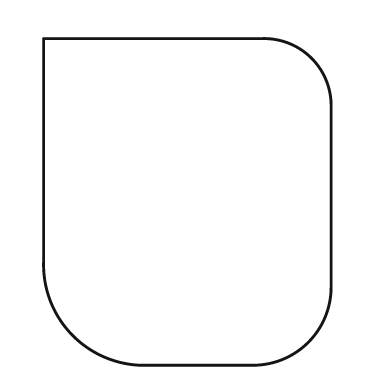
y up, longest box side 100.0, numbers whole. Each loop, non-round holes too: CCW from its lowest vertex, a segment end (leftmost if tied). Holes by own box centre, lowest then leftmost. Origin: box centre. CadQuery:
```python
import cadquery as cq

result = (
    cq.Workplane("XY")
    .moveTo(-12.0, -50.0)
    .lineTo(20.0, -50.0)
    .threePointArc((37.0, -43.0), (44.0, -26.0))
    .lineTo(44.0, 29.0)
    .threePointArc((38.0, 44.0), (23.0, 50.0))
    .lineTo(-44.0, 50.0)
    .lineTo(-44.0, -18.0)
    .threePointArc((-35.0, -41.0), (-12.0, -50.0))
    .close()
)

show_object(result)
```